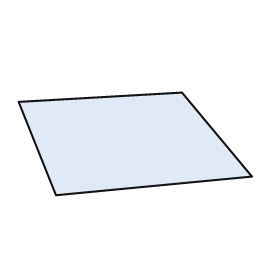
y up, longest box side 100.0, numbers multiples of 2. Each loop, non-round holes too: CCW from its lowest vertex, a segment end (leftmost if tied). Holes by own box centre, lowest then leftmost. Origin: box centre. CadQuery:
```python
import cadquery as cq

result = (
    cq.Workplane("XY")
    .moveTo(-34.0, -22.0)
    .lineTo(50.0, -14.0)
    .lineTo(20.0, 22.0)
    .lineTo(-50.0, 18.0)
    .close()
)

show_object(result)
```